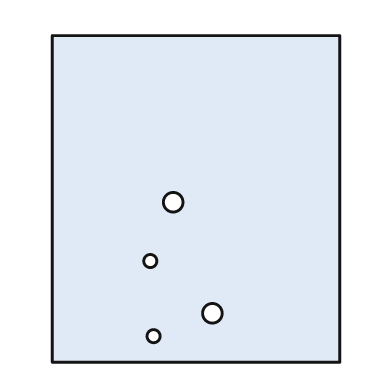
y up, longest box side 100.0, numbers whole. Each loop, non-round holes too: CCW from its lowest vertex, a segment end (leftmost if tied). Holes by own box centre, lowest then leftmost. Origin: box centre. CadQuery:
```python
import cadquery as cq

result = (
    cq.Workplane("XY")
    .moveTo(-44.0, -50.0)
    .lineTo(44.0, -50.0)
    .lineTo(44.0, 50.0)
    .lineTo(-44.0, 50.0)
    .close()
    .moveTo(-13.0, -42.0)
    .circle(2.0)
    .moveTo(5.0, -35.0)
    .circle(3.0)
    .moveTo(-14.0, -19.0)
    .circle(2.0)
    .moveTo(-7.0, -1.0)
    .circle(3.0)
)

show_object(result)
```